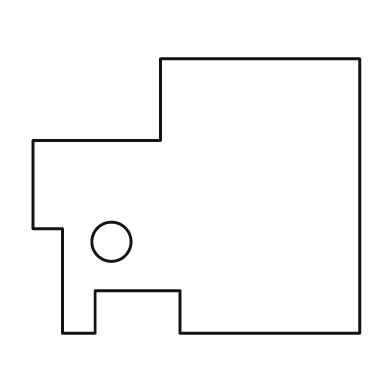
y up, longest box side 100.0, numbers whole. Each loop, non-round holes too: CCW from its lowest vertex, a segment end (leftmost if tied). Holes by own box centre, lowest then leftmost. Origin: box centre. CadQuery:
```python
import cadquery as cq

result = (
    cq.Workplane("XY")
    .moveTo(-41.0, -42.0)
    .lineTo(-31.0, -42.0)
    .lineTo(-31.0, -29.0)
    .lineTo(-5.0, -29.0)
    .lineTo(-5.0, -42.0)
    .lineTo(50.0, -42.0)
    .lineTo(50.0, 42.0)
    .lineTo(-11.0, 42.0)
    .lineTo(-11.0, 17.0)
    .lineTo(-50.0, 17.0)
    .lineTo(-50.0, -10.0)
    .lineTo(-41.0, -10.0)
    .close()
    .moveTo(-26.0, -14.0)
    .circle(6.0)
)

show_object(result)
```